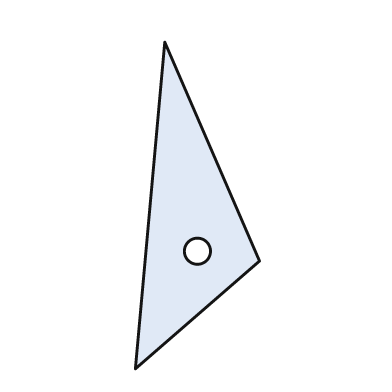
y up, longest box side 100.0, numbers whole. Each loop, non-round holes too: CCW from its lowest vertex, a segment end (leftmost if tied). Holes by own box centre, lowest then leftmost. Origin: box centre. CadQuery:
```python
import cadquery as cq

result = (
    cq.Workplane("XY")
    .moveTo(-19.0, -50.0)
    .lineTo(19.0, -17.0)
    .lineTo(-10.0, 50.0)
    .close()
    .moveTo(0.0, -14.0)
    .circle(4.0)
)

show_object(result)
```